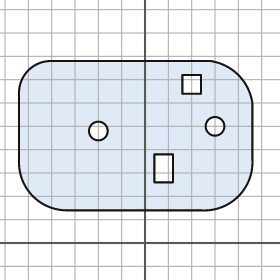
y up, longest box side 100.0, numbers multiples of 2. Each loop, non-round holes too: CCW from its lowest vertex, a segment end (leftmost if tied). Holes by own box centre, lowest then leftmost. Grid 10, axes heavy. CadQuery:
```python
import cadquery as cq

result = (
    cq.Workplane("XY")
    .moveTo(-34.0, 14.0)
    .lineTo(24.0, 14.0)
    .threePointArc((40.0, 20.0), (46.0, 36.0))
    .lineTo(46.0, 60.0)
    .threePointArc((40.0, 72.0), (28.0, 78.0))
    .lineTo(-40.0, 78.0)
    .threePointArc((-50.0, 74.0), (-54.0, 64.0))
    .lineTo(-54.0, 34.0)
    .threePointArc((-48.0, 20.0), (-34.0, 14.0))
    .close()
    .moveTo(4.0, 26.0)
    .lineTo(12.0, 26.0)
    .lineTo(12.0, 38.0)
    .lineTo(4.0, 38.0)
    .close()
    .moveTo(-20.0, 48.0)
    .circle(4.0)
    .moveTo(30.0, 50.0)
    .circle(4.0)
    .moveTo(16.0, 64.0)
    .lineTo(24.0, 64.0)
    .lineTo(24.0, 72.0)
    .lineTo(16.0, 72.0)
    .close()
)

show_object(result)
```